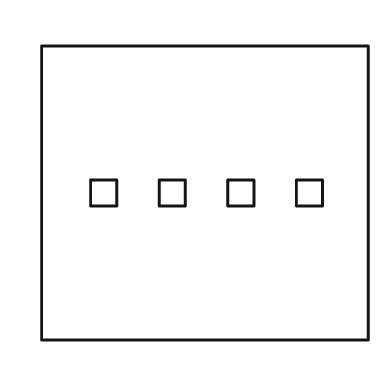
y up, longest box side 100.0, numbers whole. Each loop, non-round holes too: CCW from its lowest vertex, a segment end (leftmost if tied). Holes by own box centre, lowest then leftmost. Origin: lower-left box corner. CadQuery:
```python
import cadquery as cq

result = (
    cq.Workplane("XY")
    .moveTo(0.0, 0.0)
    .lineTo(100.0, 0.0)
    .lineTo(100.0, 90.0)
    .lineTo(0.0, 90.0)
    .close()
    .moveTo(15.0, 41.0)
    .lineTo(23.0, 41.0)
    .lineTo(23.0, 49.0)
    .lineTo(15.0, 49.0)
    .close()
    .moveTo(36.0, 41.0)
    .lineTo(44.0, 41.0)
    .lineTo(44.0, 49.0)
    .lineTo(36.0, 49.0)
    .close()
    .moveTo(57.0, 41.0)
    .lineTo(65.0, 41.0)
    .lineTo(65.0, 49.0)
    .lineTo(57.0, 49.0)
    .close()
    .moveTo(78.0, 41.0)
    .lineTo(86.0, 41.0)
    .lineTo(86.0, 49.0)
    .lineTo(78.0, 49.0)
    .close()
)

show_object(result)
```